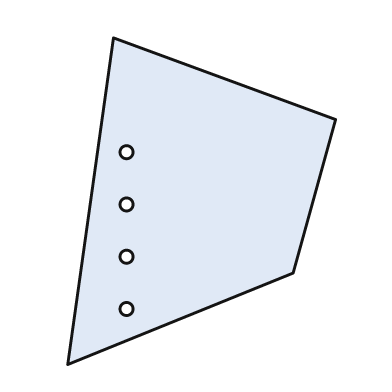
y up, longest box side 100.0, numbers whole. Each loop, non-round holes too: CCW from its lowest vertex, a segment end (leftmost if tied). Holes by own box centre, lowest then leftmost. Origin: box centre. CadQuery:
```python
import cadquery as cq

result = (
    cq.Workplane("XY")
    .moveTo(-41.0, -50.0)
    .lineTo(28.0, -22.0)
    .lineTo(41.0, 25.0)
    .lineTo(-27.0, 50.0)
    .close()
    .moveTo(-23.0, -33.0)
    .circle(2.0)
    .moveTo(-23.0, -17.0)
    .circle(2.0)
    .moveTo(-23.0, -1.0)
    .circle(2.0)
    .moveTo(-23.0, 15.0)
    .circle(2.0)
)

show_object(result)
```